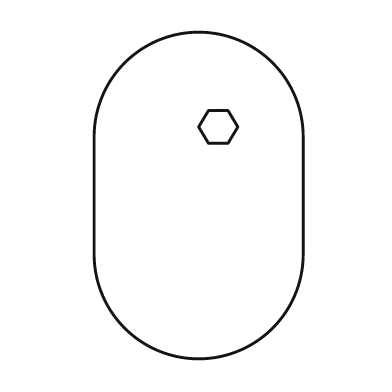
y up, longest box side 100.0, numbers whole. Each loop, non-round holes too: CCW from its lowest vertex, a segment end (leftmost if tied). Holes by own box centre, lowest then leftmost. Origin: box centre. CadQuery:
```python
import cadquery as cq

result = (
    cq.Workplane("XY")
    .moveTo(-32.0, -18.0)
    .threePointArc((0.0, -50.0), (32.0, -18.0))
    .lineTo(32.0, 18.0)
    .threePointArc((0.0, 50.0), (-32.0, 18.0))
    .close()
    .moveTo(3.0, 16.0)
    .lineTo(9.0, 16.0)
    .lineTo(12.0, 21.0)
    .lineTo(9.0, 26.0)
    .lineTo(3.0, 26.0)
    .lineTo(0.0, 21.0)
    .close()
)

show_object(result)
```